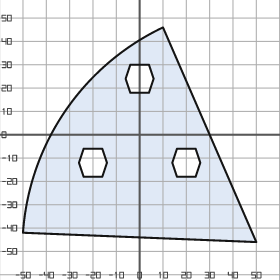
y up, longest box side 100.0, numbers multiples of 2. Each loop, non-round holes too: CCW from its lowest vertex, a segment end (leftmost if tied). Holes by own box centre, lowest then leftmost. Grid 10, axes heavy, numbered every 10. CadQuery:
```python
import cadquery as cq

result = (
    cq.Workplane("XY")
    .moveTo(50.0, -46.0)
    .lineTo(10.0, 46.0)
    .threePointArc((-32.0, 10.0), (-50.0, -42.0))
    .close()
    .moveTo(-24.0, -18.0)
    .lineTo(-16.0, -18.0)
    .lineTo(-14.0, -12.0)
    .lineTo(-16.0, -6.0)
    .lineTo(-24.0, -6.0)
    .lineTo(-26.0, -12.0)
    .close()
    .moveTo(16.0, -18.0)
    .lineTo(24.0, -18.0)
    .lineTo(26.0, -12.0)
    .lineTo(24.0, -6.0)
    .lineTo(16.0, -6.0)
    .lineTo(14.0, -12.0)
    .close()
    .moveTo(-4.0, 18.0)
    .lineTo(4.0, 18.0)
    .lineTo(6.0, 24.0)
    .lineTo(4.0, 30.0)
    .lineTo(-4.0, 30.0)
    .lineTo(-6.0, 24.0)
    .close()
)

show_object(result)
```